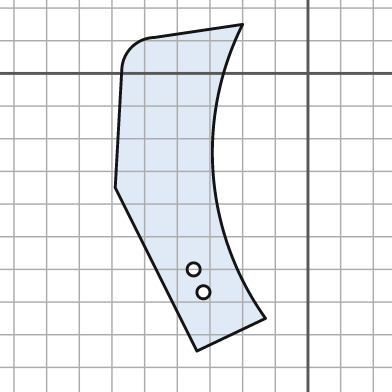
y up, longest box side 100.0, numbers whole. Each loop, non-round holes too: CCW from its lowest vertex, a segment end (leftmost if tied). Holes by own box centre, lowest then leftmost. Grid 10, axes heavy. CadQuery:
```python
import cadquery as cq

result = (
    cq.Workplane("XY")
    .moveTo(-34.0, -85.0)
    .lineTo(-13.0, -75.0)
    .threePointArc((-29.0, -31.0), (-20.0, 15.0))
    .lineTo(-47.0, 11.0)
    .threePointArc((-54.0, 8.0), (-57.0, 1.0))
    .lineTo(-59.0, -35.0)
    .close()
    .moveTo(-32.0, -67.0)
    .circle(2.0)
    .moveTo(-35.0, -60.0)
    .circle(2.0)
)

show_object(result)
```